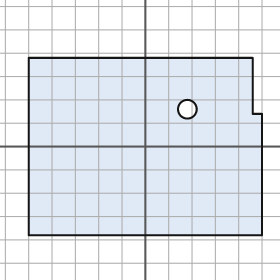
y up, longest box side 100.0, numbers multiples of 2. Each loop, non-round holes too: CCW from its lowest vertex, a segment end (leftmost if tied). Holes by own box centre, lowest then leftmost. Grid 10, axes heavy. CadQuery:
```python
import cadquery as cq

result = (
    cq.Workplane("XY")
    .moveTo(-50.0, -38.0)
    .lineTo(50.0, -38.0)
    .lineTo(50.0, 14.0)
    .lineTo(46.0, 14.0)
    .lineTo(46.0, 38.0)
    .lineTo(-50.0, 38.0)
    .close()
    .moveTo(18.0, 16.0)
    .circle(4.0)
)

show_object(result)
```